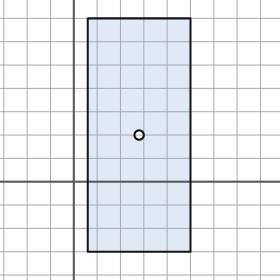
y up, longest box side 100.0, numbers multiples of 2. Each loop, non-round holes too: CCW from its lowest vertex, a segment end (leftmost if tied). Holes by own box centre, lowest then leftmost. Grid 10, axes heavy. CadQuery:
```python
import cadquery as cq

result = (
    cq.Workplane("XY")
    .moveTo(6.0, -30.0)
    .lineTo(50.0, -30.0)
    .lineTo(50.0, 70.0)
    .lineTo(6.0, 70.0)
    .close()
    .moveTo(28.0, 20.0)
    .circle(2.0)
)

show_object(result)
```